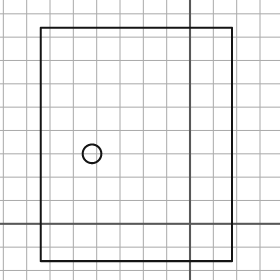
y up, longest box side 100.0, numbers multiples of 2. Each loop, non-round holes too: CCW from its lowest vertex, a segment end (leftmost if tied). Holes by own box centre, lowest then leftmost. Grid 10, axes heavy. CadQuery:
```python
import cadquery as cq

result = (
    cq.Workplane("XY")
    .moveTo(-64.0, -16.0)
    .lineTo(18.0, -16.0)
    .lineTo(18.0, 84.0)
    .lineTo(-64.0, 84.0)
    .close()
    .moveTo(-42.0, 30.0)
    .circle(4.0)
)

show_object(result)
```